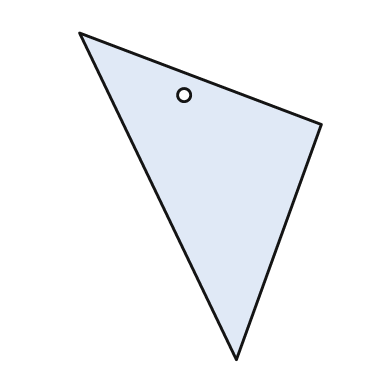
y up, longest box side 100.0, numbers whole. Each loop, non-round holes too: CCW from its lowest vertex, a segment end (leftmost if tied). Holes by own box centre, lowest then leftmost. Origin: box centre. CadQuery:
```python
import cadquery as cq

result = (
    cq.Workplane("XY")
    .moveTo(11.0, -50.0)
    .lineTo(37.0, 22.0)
    .lineTo(-37.0, 50.0)
    .close()
    .moveTo(-5.0, 31.0)
    .circle(2.0)
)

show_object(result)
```